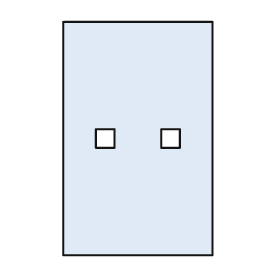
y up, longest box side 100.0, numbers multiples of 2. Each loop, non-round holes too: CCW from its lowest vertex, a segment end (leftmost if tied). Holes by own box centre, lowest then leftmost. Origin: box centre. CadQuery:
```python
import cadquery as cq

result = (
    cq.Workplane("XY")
    .moveTo(-32.0, -50.0)
    .lineTo(32.0, -50.0)
    .lineTo(32.0, 50.0)
    .lineTo(-32.0, 50.0)
    .close()
    .moveTo(-18.0, -4.0)
    .lineTo(-10.0, -4.0)
    .lineTo(-10.0, 4.0)
    .lineTo(-18.0, 4.0)
    .close()
    .moveTo(10.0, -4.0)
    .lineTo(18.0, -4.0)
    .lineTo(18.0, 4.0)
    .lineTo(10.0, 4.0)
    .close()
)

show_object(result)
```